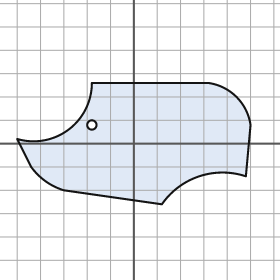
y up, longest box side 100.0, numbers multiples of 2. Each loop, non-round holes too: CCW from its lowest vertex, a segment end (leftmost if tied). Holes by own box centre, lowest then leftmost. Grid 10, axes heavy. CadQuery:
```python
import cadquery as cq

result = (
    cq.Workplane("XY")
    .moveTo(12.0, -26.0)
    .threePointArc((28.0, -14.0), (48.0, -14.0))
    .lineTo(50.0, 8.0)
    .threePointArc((44.0, 20.0), (32.0, 26.0))
    .lineTo(-18.0, 26.0)
    .threePointArc((-28.0, 6.0), (-50.0, 2.0))
    .lineTo(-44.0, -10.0)
    .threePointArc((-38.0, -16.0), (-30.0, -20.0))
    .close()
    .moveTo(-18.0, 8.0)
    .circle(2.0)
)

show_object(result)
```